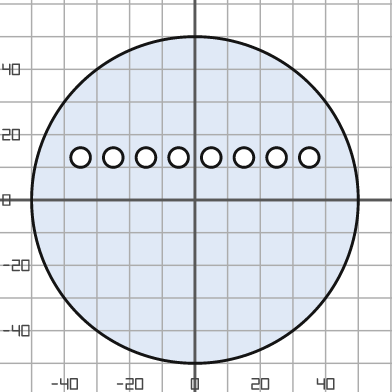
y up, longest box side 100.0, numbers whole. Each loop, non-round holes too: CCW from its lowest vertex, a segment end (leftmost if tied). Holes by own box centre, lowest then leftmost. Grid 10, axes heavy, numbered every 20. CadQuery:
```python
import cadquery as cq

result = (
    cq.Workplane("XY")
    .moveTo(0.0, 0.0)
    .circle(50.0)
    .moveTo(-35.0, 13.0)
    .circle(3.0)
    .moveTo(-25.0, 13.0)
    .circle(3.0)
    .moveTo(-15.0, 13.0)
    .circle(3.0)
    .moveTo(-5.0, 13.0)
    .circle(3.0)
    .moveTo(5.0, 13.0)
    .circle(3.0)
    .moveTo(15.0, 13.0)
    .circle(3.0)
    .moveTo(25.0, 13.0)
    .circle(3.0)
    .moveTo(35.0, 13.0)
    .circle(3.0)
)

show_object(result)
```